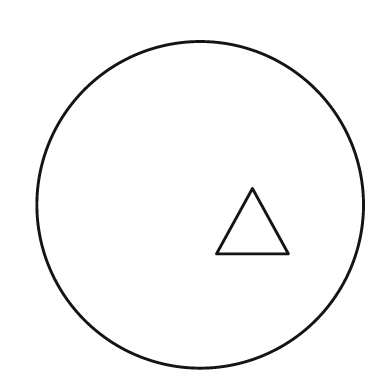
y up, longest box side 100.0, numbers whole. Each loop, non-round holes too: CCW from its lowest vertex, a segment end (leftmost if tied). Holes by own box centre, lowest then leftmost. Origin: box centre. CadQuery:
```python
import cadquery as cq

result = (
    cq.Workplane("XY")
    .moveTo(0.0, 0.0)
    .circle(50.0)
    .moveTo(5.0, -15.0)
    .lineTo(27.0, -15.0)
    .lineTo(16.0, 5.0)
    .close()
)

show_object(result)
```